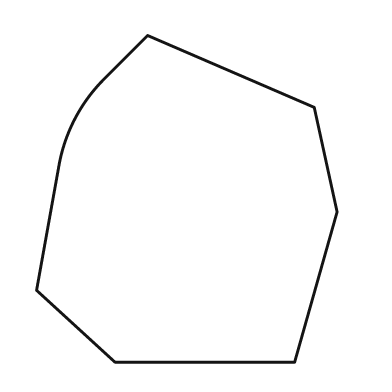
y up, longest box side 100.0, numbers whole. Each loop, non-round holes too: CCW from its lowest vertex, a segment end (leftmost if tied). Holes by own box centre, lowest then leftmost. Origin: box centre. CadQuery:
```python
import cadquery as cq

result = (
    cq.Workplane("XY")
    .moveTo(-22.0, -50.0)
    .lineTo(33.0, -50.0)
    .lineTo(46.0, -4.0)
    .lineTo(39.0, 28.0)
    .lineTo(-12.0, 50.0)
    .lineTo(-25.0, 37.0)
    .threePointArc((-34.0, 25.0), (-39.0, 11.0))
    .lineTo(-46.0, -28.0)
    .close()
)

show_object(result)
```